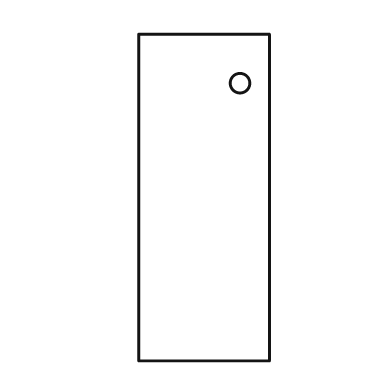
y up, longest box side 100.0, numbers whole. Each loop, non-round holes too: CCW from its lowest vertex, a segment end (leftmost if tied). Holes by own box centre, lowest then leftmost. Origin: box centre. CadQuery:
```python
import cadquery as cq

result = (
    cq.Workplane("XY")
    .moveTo(-20.0, -50.0)
    .lineTo(20.0, -50.0)
    .lineTo(20.0, 50.0)
    .lineTo(-20.0, 50.0)
    .close()
    .moveTo(11.0, 35.0)
    .circle(3.0)
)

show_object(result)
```